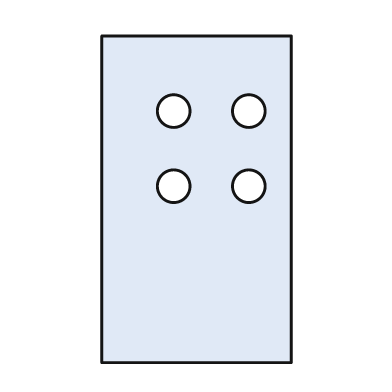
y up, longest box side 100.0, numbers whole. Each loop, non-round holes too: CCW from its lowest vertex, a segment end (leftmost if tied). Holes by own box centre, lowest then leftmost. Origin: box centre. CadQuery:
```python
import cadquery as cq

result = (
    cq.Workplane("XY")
    .moveTo(-29.0, -50.0)
    .lineTo(29.0, -50.0)
    .lineTo(29.0, 50.0)
    .lineTo(-29.0, 50.0)
    .close()
    .moveTo(-7.0, 4.0)
    .circle(5.0)
    .moveTo(16.0, 4.0)
    .circle(5.0)
    .moveTo(-7.0, 27.0)
    .circle(5.0)
    .moveTo(16.0, 27.0)
    .circle(5.0)
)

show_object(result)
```